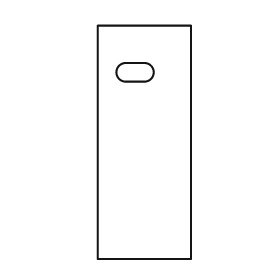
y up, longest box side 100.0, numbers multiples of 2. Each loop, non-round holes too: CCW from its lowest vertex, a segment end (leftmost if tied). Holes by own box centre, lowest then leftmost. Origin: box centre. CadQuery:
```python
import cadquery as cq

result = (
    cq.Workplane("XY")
    .moveTo(-20.0, -50.0)
    .lineTo(20.0, -50.0)
    .lineTo(20.0, 50.0)
    .lineTo(-20.0, 50.0)
    .close()
    .moveTo(-8.0, 26.0)
    .lineTo(0.0, 26.0)
    .threePointArc((4.0, 30.0), (0.0, 34.0))
    .lineTo(-8.0, 34.0)
    .threePointArc((-12.0, 30.0), (-8.0, 26.0))
    .close()
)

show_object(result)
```